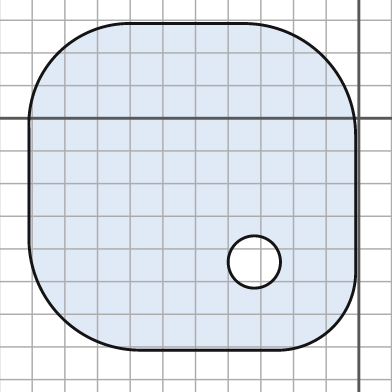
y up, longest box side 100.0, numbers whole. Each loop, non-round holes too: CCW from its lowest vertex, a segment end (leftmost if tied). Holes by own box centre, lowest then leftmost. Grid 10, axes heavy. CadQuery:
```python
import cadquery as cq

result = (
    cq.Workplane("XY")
    .moveTo(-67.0, -71.0)
    .lineTo(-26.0, -71.0)
    .threePointArc((-8.0, -64.0), (-1.0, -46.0))
    .lineTo(-1.0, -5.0)
    .threePointArc((-11.0, 19.0), (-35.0, 29.0))
    .lineTo(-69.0, 29.0)
    .threePointArc((-92.0, 20.0), (-101.0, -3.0))
    .lineTo(-101.0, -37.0)
    .threePointArc((-91.0, -61.0), (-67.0, -71.0))
    .close()
    .moveTo(-32.0, -44.0)
    .circle(8.0)
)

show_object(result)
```